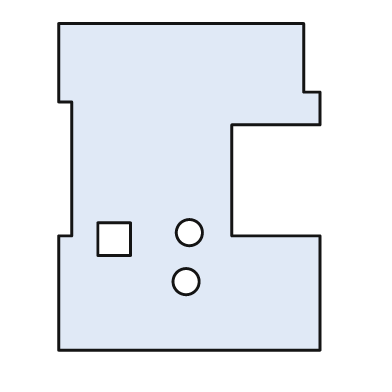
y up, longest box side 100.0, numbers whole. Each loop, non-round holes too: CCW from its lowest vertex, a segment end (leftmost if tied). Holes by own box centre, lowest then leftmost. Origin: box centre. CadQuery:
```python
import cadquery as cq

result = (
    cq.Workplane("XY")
    .moveTo(-40.0, -50.0)
    .lineTo(40.0, -50.0)
    .lineTo(40.0, -15.0)
    .lineTo(13.0, -15.0)
    .lineTo(13.0, 19.0)
    .lineTo(40.0, 19.0)
    .lineTo(40.0, 29.0)
    .lineTo(35.0, 29.0)
    .lineTo(35.0, 50.0)
    .lineTo(-40.0, 50.0)
    .lineTo(-40.0, 26.0)
    .lineTo(-36.0, 26.0)
    .lineTo(-36.0, -15.0)
    .lineTo(-40.0, -15.0)
    .close()
    .moveTo(-1.0, -29.0)
    .circle(4.0)
    .moveTo(-28.0, -21.0)
    .lineTo(-18.0, -21.0)
    .lineTo(-18.0, -11.0)
    .lineTo(-28.0, -11.0)
    .close()
    .moveTo(0.0, -14.0)
    .circle(4.0)
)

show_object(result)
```